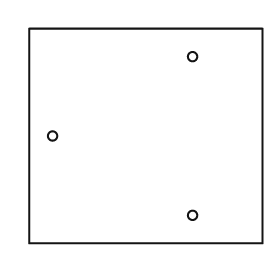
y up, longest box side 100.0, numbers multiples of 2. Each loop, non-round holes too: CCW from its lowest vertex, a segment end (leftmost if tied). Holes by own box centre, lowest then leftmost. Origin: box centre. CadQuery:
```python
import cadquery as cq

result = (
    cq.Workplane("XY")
    .moveTo(-50.0, -46.0)
    .lineTo(50.0, -46.0)
    .lineTo(50.0, 46.0)
    .lineTo(-50.0, 46.0)
    .close()
    .moveTo(20.0, -34.0)
    .circle(2.0)
    .moveTo(-40.0, 0.0)
    .circle(2.0)
    .moveTo(20.0, 34.0)
    .circle(2.0)
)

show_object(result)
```